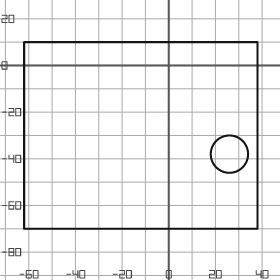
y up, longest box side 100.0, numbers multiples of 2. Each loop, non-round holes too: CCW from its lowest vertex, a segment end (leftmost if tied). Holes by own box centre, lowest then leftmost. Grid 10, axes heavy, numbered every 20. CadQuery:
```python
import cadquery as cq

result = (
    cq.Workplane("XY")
    .moveTo(-62.0, -70.0)
    .lineTo(38.0, -70.0)
    .lineTo(38.0, 10.0)
    .lineTo(-62.0, 10.0)
    .close()
    .moveTo(26.0, -38.0)
    .circle(8.0)
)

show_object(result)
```